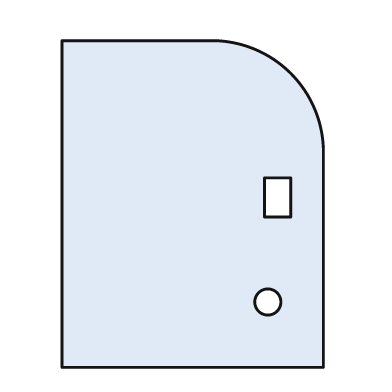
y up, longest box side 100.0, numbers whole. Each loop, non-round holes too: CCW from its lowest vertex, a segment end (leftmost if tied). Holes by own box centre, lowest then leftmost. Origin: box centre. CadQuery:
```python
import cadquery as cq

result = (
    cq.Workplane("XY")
    .moveTo(-40.0, -50.0)
    .lineTo(40.0, -50.0)
    .lineTo(40.0, 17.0)
    .threePointArc((30.0, 40.0), (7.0, 50.0))
    .lineTo(-40.0, 50.0)
    .close()
    .moveTo(23.0, -30.0)
    .circle(4.0)
    .moveTo(22.0, -4.0)
    .lineTo(30.0, -4.0)
    .lineTo(30.0, 8.0)
    .lineTo(22.0, 8.0)
    .close()
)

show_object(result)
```